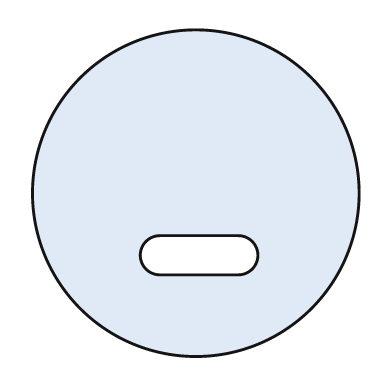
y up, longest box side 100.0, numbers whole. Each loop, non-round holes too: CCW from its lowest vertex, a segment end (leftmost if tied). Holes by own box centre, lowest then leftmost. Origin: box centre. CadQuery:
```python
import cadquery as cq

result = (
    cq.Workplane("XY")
    .moveTo(0.0, 0.0)
    .circle(50.0)
    .moveTo(-11.0, -25.0)
    .lineTo(13.0, -25.0)
    .threePointArc((19.0, -19.0), (13.0, -13.0))
    .lineTo(-11.0, -13.0)
    .threePointArc((-17.0, -19.0), (-11.0, -25.0))
    .close()
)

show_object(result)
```